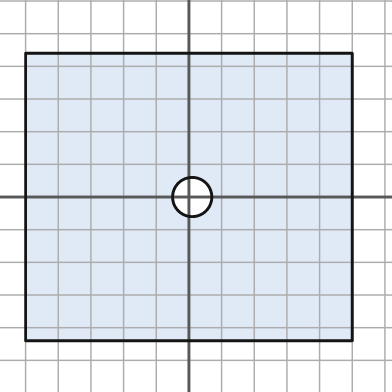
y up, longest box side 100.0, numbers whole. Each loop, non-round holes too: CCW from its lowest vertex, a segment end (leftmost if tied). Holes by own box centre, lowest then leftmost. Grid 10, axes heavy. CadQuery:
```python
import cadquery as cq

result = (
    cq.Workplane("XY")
    .moveTo(-50.0, -44.0)
    .lineTo(50.0, -44.0)
    .lineTo(50.0, 44.0)
    .lineTo(-50.0, 44.0)
    .close()
    .moveTo(1.0, 0.0)
    .circle(6.0)
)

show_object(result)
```